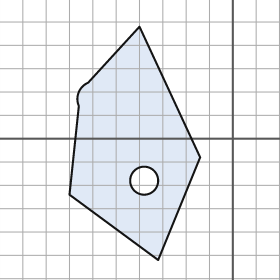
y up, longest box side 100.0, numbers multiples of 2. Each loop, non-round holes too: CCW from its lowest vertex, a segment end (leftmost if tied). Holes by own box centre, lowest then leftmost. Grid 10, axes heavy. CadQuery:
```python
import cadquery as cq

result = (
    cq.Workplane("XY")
    .moveTo(-32.0, -52.0)
    .lineTo(-14.0, -8.0)
    .lineTo(-40.0, 48.0)
    .lineTo(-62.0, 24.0)
    .threePointArc((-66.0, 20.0), (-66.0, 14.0))
    .lineTo(-70.0, -24.0)
    .close()
    .moveTo(-38.0, -18.0)
    .circle(6.0)
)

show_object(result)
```